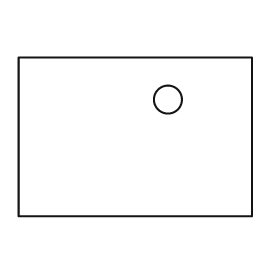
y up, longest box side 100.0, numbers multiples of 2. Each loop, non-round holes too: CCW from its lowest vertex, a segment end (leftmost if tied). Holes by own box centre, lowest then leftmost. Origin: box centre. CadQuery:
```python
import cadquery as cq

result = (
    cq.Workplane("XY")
    .moveTo(-50.0, -34.0)
    .lineTo(50.0, -34.0)
    .lineTo(50.0, 34.0)
    .lineTo(-50.0, 34.0)
    .close()
    .moveTo(14.0, 16.0)
    .circle(6.0)
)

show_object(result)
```